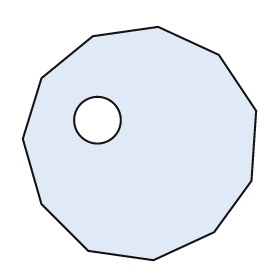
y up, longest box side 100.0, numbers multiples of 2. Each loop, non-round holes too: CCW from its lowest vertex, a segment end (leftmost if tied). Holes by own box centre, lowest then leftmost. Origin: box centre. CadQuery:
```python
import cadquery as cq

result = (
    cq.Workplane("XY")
    .moveTo(6.0, -50.0)
    .lineTo(32.0, -38.0)
    .lineTo(48.0, -16.0)
    .lineTo(50.0, 14.0)
    .lineTo(34.0, 38.0)
    .lineTo(8.0, 50.0)
    .lineTo(-20.0, 46.0)
    .lineTo(-42.0, 28.0)
    .lineTo(-50.0, 2.0)
    .lineTo(-42.0, -26.0)
    .lineTo(-22.0, -46.0)
    .close()
    .moveTo(-18.0, 10.0)
    .circle(10.0)
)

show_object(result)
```